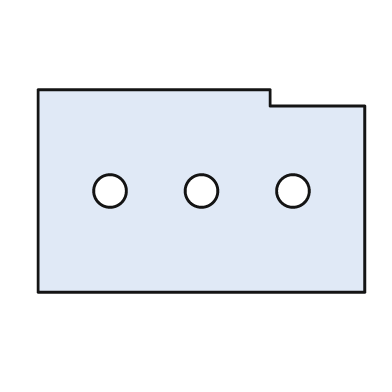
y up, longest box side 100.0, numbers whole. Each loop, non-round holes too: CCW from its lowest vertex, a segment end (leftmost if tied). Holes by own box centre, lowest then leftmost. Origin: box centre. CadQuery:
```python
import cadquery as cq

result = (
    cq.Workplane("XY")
    .moveTo(-50.0, -31.0)
    .lineTo(50.0, -31.0)
    .lineTo(50.0, 26.0)
    .lineTo(21.0, 26.0)
    .lineTo(21.0, 31.0)
    .lineTo(-50.0, 31.0)
    .close()
    .moveTo(-28.0, 0.0)
    .circle(5.0)
    .moveTo(0.0, 0.0)
    .circle(5.0)
    .moveTo(28.0, 0.0)
    .circle(5.0)
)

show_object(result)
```